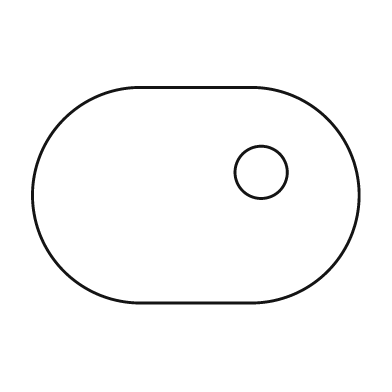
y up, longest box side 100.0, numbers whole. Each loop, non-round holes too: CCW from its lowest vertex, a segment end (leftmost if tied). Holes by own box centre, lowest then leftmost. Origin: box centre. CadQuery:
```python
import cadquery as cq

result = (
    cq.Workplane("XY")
    .moveTo(-17.0, -33.0)
    .lineTo(17.0, -33.0)
    .threePointArc((50.0, 0.0), (17.0, 33.0))
    .lineTo(-17.0, 33.0)
    .threePointArc((-50.0, 0.0), (-17.0, -33.0))
    .close()
    .moveTo(20.0, 7.0)
    .circle(8.0)
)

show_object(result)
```